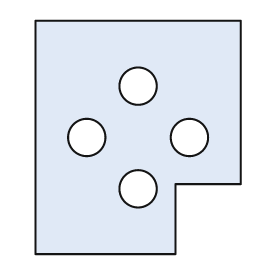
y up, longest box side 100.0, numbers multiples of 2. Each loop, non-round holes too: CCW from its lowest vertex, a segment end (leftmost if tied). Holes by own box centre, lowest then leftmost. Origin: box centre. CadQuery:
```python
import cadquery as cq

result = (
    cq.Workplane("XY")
    .moveTo(-44.0, -50.0)
    .lineTo(16.0, -50.0)
    .lineTo(16.0, -20.0)
    .lineTo(44.0, -20.0)
    .lineTo(44.0, 50.0)
    .lineTo(-44.0, 50.0)
    .close()
    .moveTo(0.0, -22.0)
    .circle(8.0)
    .moveTo(-22.0, 0.0)
    .circle(8.0)
    .moveTo(22.0, 0.0)
    .circle(8.0)
    .moveTo(0.0, 22.0)
    .circle(8.0)
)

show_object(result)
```